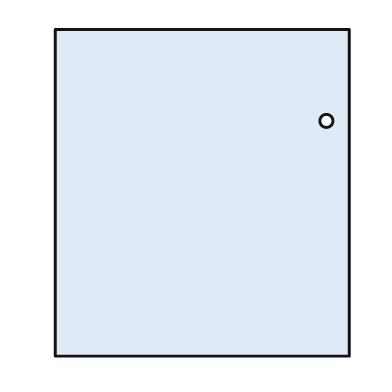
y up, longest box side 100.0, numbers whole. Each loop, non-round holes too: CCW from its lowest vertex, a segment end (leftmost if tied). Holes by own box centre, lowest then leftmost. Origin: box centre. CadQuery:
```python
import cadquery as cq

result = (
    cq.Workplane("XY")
    .moveTo(-45.0, -50.0)
    .lineTo(45.0, -50.0)
    .lineTo(45.0, 50.0)
    .lineTo(-45.0, 50.0)
    .close()
    .moveTo(38.0, 22.0)
    .circle(2.0)
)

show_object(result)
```